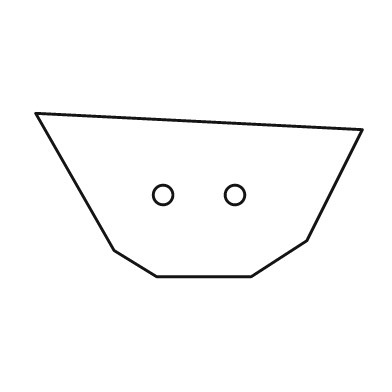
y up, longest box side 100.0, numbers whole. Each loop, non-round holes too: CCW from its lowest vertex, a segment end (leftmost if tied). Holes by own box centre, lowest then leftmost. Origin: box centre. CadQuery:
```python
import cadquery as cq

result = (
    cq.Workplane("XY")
    .moveTo(-13.0, -25.0)
    .lineTo(16.0, -25.0)
    .lineTo(33.0, -14.0)
    .lineTo(50.0, 20.0)
    .lineTo(-50.0, 25.0)
    .lineTo(-26.0, -17.0)
    .close()
    .moveTo(-11.0, 0.0)
    .circle(3.0)
    .moveTo(11.0, 0.0)
    .circle(3.0)
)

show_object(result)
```